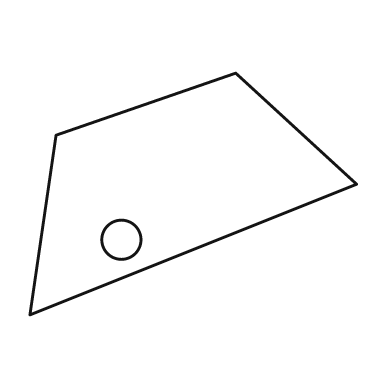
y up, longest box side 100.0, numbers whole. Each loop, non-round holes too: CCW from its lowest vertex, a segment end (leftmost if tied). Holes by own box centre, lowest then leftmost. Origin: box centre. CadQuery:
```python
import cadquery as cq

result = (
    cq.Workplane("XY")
    .moveTo(-50.0, -37.0)
    .lineTo(50.0, 3.0)
    .lineTo(13.0, 37.0)
    .lineTo(-42.0, 18.0)
    .close()
    .moveTo(-22.0, -14.0)
    .circle(6.0)
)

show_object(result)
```